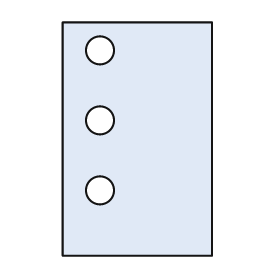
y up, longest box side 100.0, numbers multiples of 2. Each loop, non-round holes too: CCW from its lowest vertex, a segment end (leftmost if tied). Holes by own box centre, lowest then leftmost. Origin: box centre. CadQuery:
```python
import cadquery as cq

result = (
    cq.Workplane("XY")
    .moveTo(-32.0, -50.0)
    .lineTo(32.0, -50.0)
    .lineTo(32.0, 50.0)
    .lineTo(-32.0, 50.0)
    .close()
    .moveTo(-16.0, -22.0)
    .circle(6.0)
    .moveTo(-16.0, 8.0)
    .circle(6.0)
    .moveTo(-16.0, 38.0)
    .circle(6.0)
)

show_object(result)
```